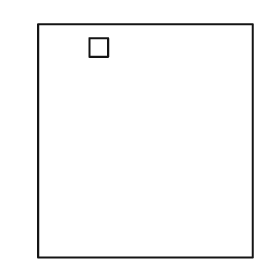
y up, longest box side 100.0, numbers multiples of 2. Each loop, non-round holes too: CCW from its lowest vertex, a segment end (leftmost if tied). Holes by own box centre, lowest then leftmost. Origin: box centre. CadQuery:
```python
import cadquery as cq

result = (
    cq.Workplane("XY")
    .moveTo(-46.0, -50.0)
    .lineTo(46.0, -50.0)
    .lineTo(46.0, 50.0)
    .lineTo(-46.0, 50.0)
    .close()
    .moveTo(-24.0, 36.0)
    .lineTo(-16.0, 36.0)
    .lineTo(-16.0, 44.0)
    .lineTo(-24.0, 44.0)
    .close()
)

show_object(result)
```